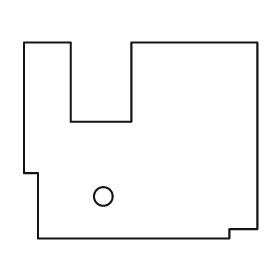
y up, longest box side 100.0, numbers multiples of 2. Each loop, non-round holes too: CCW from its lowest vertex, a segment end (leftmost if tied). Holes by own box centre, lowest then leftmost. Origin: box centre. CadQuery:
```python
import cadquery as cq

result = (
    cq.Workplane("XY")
    .moveTo(-44.0, -42.0)
    .lineTo(38.0, -42.0)
    .lineTo(38.0, -38.0)
    .lineTo(50.0, -38.0)
    .lineTo(50.0, 42.0)
    .lineTo(-4.0, 42.0)
    .lineTo(-4.0, 8.0)
    .lineTo(-30.0, 8.0)
    .lineTo(-30.0, 42.0)
    .lineTo(-50.0, 42.0)
    .lineTo(-50.0, -14.0)
    .lineTo(-44.0, -14.0)
    .close()
    .moveTo(-16.0, -24.0)
    .circle(4.0)
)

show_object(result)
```